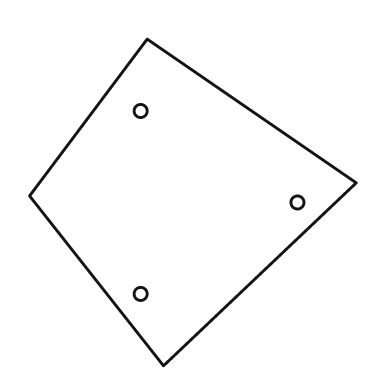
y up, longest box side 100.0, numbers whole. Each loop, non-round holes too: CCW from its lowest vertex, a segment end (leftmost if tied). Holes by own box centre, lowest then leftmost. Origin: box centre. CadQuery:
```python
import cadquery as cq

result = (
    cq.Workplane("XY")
    .moveTo(-9.0, -50.0)
    .lineTo(50.0, 6.0)
    .lineTo(-14.0, 50.0)
    .lineTo(-50.0, 2.0)
    .close()
    .moveTo(-16.0, -28.0)
    .circle(2.0)
    .moveTo(32.0, 0.0)
    .circle(2.0)
    .moveTo(-16.0, 28.0)
    .circle(2.0)
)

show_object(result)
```